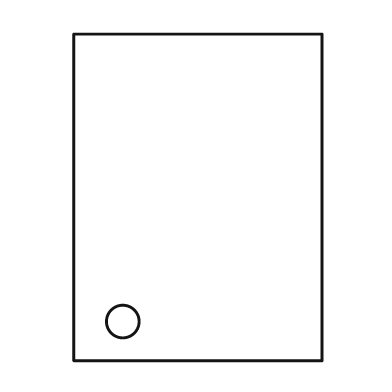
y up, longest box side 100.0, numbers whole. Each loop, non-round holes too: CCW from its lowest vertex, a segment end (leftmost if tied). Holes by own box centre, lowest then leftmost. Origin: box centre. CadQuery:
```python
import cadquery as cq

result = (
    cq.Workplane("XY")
    .moveTo(-38.0, -50.0)
    .lineTo(38.0, -50.0)
    .lineTo(38.0, 50.0)
    .lineTo(-38.0, 50.0)
    .close()
    .moveTo(-23.0, -38.0)
    .circle(5.0)
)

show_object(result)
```